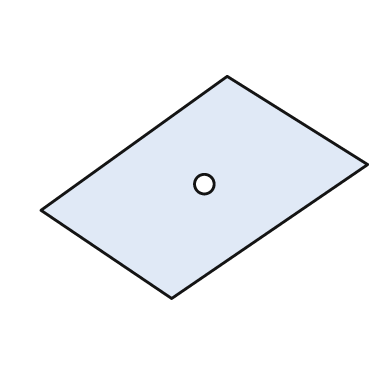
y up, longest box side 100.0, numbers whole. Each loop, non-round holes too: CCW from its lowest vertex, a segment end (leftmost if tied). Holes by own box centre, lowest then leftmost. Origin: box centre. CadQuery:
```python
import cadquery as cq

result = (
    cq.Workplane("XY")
    .moveTo(-10.0, -34.0)
    .lineTo(50.0, 7.0)
    .lineTo(7.0, 34.0)
    .lineTo(-50.0, -7.0)
    .close()
    .moveTo(0.0, 1.0)
    .circle(3.0)
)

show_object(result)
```